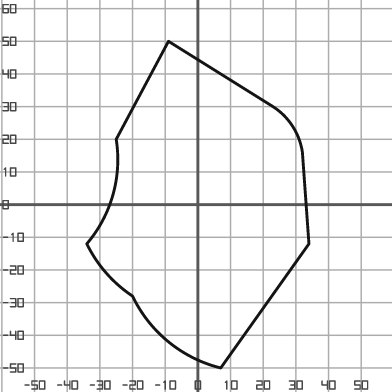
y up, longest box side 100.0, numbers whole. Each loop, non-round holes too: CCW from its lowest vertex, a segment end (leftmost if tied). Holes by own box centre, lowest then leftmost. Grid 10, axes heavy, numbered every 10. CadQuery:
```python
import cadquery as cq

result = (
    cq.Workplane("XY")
    .moveTo(7.0, -50.0)
    .lineTo(34.0, -12.0)
    .lineTo(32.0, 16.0)
    .threePointArc((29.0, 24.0), (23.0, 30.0))
    .lineTo(-9.0, 50.0)
    .lineTo(-25.0, 20.0)
    .threePointArc((-26.0, 3.0), (-34.0, -12.0))
    .threePointArc((-28.0, -21.0), (-20.0, -28.0))
    .threePointArc((-9.0, -42.0), (7.0, -50.0))
    .close()
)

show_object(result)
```